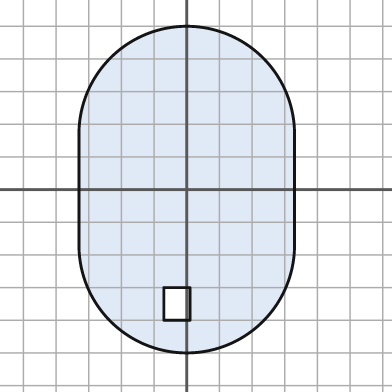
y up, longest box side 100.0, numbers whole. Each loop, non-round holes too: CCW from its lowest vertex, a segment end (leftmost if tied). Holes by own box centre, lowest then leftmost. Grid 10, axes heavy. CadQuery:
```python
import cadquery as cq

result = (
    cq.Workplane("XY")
    .moveTo(-33.0, -17.0)
    .threePointArc((0.0, -50.0), (33.0, -17.0))
    .lineTo(33.0, 17.0)
    .threePointArc((0.0, 50.0), (-33.0, 17.0))
    .close()
    .moveTo(-7.0, -40.0)
    .lineTo(1.0, -40.0)
    .lineTo(1.0, -30.0)
    .lineTo(-7.0, -30.0)
    .close()
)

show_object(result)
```